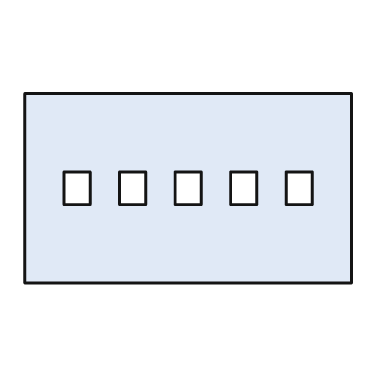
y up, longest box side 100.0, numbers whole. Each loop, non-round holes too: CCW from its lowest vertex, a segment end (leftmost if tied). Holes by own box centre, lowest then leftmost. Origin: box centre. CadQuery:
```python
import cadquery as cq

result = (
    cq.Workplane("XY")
    .moveTo(-50.0, -29.0)
    .lineTo(50.0, -29.0)
    .lineTo(50.0, 29.0)
    .lineTo(-50.0, 29.0)
    .close()
    .moveTo(-38.0, -5.0)
    .lineTo(-30.0, -5.0)
    .lineTo(-30.0, 5.0)
    .lineTo(-38.0, 5.0)
    .close()
    .moveTo(-21.0, -5.0)
    .lineTo(-13.0, -5.0)
    .lineTo(-13.0, 5.0)
    .lineTo(-21.0, 5.0)
    .close()
    .moveTo(-4.0, -5.0)
    .lineTo(4.0, -5.0)
    .lineTo(4.0, 5.0)
    .lineTo(-4.0, 5.0)
    .close()
    .moveTo(13.0, -5.0)
    .lineTo(21.0, -5.0)
    .lineTo(21.0, 5.0)
    .lineTo(13.0, 5.0)
    .close()
    .moveTo(30.0, -5.0)
    .lineTo(38.0, -5.0)
    .lineTo(38.0, 5.0)
    .lineTo(30.0, 5.0)
    .close()
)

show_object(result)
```